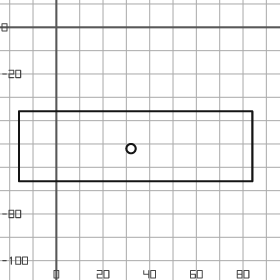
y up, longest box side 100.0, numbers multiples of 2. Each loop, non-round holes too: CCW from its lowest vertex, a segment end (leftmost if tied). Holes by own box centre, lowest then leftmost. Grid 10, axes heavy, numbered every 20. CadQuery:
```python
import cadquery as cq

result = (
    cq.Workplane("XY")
    .moveTo(-16.0, -66.0)
    .lineTo(84.0, -66.0)
    .lineTo(84.0, -36.0)
    .lineTo(-16.0, -36.0)
    .close()
    .moveTo(32.0, -52.0)
    .circle(2.0)
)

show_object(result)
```